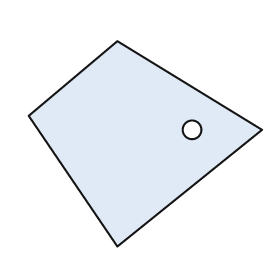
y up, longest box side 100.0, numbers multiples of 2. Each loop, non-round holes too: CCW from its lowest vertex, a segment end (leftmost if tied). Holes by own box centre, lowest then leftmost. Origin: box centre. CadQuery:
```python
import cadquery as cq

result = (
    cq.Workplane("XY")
    .moveTo(-12.0, -44.0)
    .lineTo(50.0, 6.0)
    .lineTo(-12.0, 44.0)
    .lineTo(-50.0, 12.0)
    .close()
    .moveTo(20.0, 6.0)
    .circle(4.0)
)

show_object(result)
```